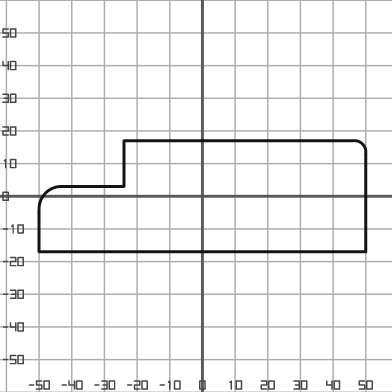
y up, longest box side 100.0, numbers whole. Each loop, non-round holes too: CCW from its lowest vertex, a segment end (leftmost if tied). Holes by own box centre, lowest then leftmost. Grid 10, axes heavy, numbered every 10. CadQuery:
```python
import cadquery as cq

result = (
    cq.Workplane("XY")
    .moveTo(-50.0, -17.0)
    .lineTo(50.0, -17.0)
    .lineTo(50.0, 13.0)
    .threePointArc((49.0, 16.0), (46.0, 17.0))
    .lineTo(-24.0, 17.0)
    .lineTo(-24.0, 3.0)
    .lineTo(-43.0, 3.0)
    .threePointArc((-48.0, 1.0), (-50.0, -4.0))
    .close()
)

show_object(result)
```